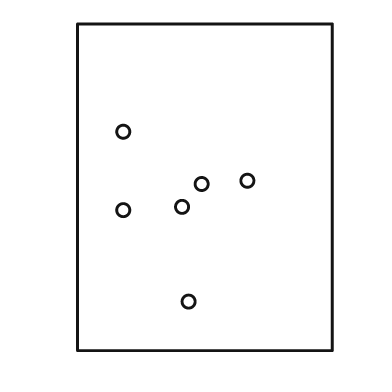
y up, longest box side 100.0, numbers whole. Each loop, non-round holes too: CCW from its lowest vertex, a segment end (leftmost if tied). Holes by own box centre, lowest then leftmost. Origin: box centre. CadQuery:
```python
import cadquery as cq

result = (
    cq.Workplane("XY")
    .moveTo(-39.0, -50.0)
    .lineTo(39.0, -50.0)
    .lineTo(39.0, 50.0)
    .lineTo(-39.0, 50.0)
    .close()
    .moveTo(-5.0, -35.0)
    .circle(2.0)
    .moveTo(-25.0, -7.0)
    .circle(2.0)
    .moveTo(-7.0, -6.0)
    .circle(2.0)
    .moveTo(-1.0, 1.0)
    .circle(2.0)
    .moveTo(13.0, 2.0)
    .circle(2.0)
    .moveTo(-25.0, 17.0)
    .circle(2.0)
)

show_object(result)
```